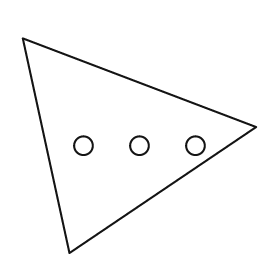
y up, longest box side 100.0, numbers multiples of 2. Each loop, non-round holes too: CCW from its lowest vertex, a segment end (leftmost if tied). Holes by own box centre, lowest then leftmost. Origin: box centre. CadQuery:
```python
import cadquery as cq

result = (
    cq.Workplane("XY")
    .moveTo(-30.0, -46.0)
    .lineTo(50.0, 8.0)
    .lineTo(-50.0, 46.0)
    .close()
    .moveTo(-24.0, 0.0)
    .circle(4.0)
    .moveTo(0.0, 0.0)
    .circle(4.0)
    .moveTo(24.0, 0.0)
    .circle(4.0)
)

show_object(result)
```